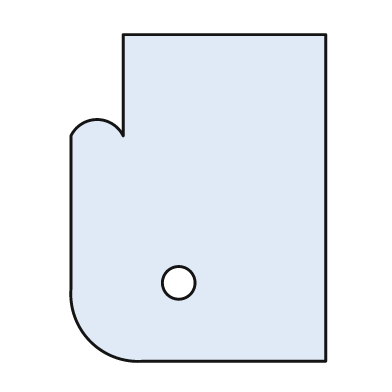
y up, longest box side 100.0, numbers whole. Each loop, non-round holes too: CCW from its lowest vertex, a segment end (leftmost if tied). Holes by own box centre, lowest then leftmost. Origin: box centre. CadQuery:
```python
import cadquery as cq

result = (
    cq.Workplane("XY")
    .moveTo(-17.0, -50.0)
    .lineTo(39.0, -50.0)
    .lineTo(39.0, 50.0)
    .lineTo(-23.0, 50.0)
    .lineTo(-23.0, 19.0)
    .threePointArc((-31.0, 24.0), (-39.0, 19.0))
    .lineTo(-39.0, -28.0)
    .threePointArc((-33.0, -44.0), (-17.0, -50.0))
    .close()
    .moveTo(-6.0, -26.0)
    .circle(5.0)
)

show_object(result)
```